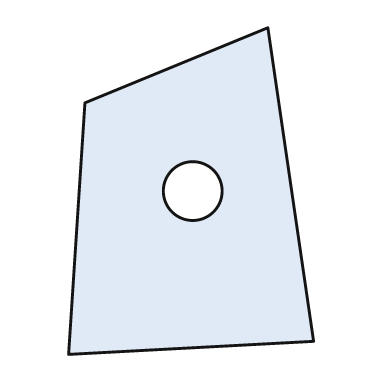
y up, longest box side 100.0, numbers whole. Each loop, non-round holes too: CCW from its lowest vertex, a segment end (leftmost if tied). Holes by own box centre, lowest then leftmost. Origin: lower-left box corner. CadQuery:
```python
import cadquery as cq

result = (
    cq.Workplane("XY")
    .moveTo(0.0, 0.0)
    .lineTo(75.0, 4.0)
    .lineTo(61.0, 100.0)
    .lineTo(5.0, 77.0)
    .close()
    .moveTo(38.0, 50.0)
    .circle(9.0)
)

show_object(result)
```